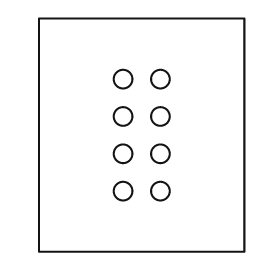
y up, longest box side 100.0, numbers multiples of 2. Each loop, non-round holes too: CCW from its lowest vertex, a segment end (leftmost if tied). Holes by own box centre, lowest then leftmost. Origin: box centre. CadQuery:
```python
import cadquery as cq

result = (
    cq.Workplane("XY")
    .moveTo(-44.0, -50.0)
    .lineTo(44.0, -50.0)
    .lineTo(44.0, 50.0)
    .lineTo(-44.0, 50.0)
    .close()
    .moveTo(-8.0, -24.0)
    .circle(4.0)
    .moveTo(8.0, -24.0)
    .circle(4.0)
    .moveTo(-8.0, -8.0)
    .circle(4.0)
    .moveTo(8.0, -8.0)
    .circle(4.0)
    .moveTo(-8.0, 8.0)
    .circle(4.0)
    .moveTo(8.0, 8.0)
    .circle(4.0)
    .moveTo(-8.0, 24.0)
    .circle(4.0)
    .moveTo(8.0, 24.0)
    .circle(4.0)
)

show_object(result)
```